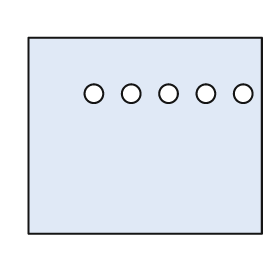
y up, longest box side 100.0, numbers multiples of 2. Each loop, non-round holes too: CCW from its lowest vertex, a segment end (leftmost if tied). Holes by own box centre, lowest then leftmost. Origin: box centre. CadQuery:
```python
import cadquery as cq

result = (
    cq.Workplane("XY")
    .moveTo(-50.0, -42.0)
    .lineTo(50.0, -42.0)
    .lineTo(50.0, 42.0)
    .lineTo(-50.0, 42.0)
    .close()
    .moveTo(-22.0, 18.0)
    .circle(4.0)
    .moveTo(-6.0, 18.0)
    .circle(4.0)
    .moveTo(10.0, 18.0)
    .circle(4.0)
    .moveTo(26.0, 18.0)
    .circle(4.0)
    .moveTo(42.0, 18.0)
    .circle(4.0)
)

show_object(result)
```